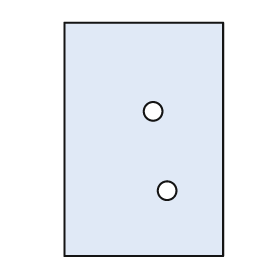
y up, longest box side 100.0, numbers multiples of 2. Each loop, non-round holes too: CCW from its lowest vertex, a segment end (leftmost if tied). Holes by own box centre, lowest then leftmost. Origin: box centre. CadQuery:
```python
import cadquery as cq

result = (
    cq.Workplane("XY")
    .moveTo(-34.0, -50.0)
    .lineTo(34.0, -50.0)
    .lineTo(34.0, 50.0)
    .lineTo(-34.0, 50.0)
    .close()
    .moveTo(10.0, -22.0)
    .circle(4.0)
    .moveTo(4.0, 12.0)
    .circle(4.0)
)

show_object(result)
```